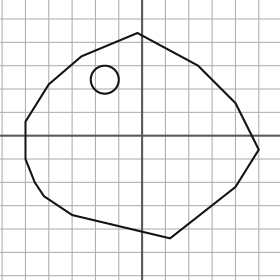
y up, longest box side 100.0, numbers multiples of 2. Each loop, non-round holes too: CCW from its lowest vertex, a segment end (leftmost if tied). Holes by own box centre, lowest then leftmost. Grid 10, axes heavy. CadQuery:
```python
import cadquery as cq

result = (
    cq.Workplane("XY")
    .moveTo(12.0, -44.0)
    .lineTo(40.0, -22.0)
    .lineTo(50.0, -6.0)
    .lineTo(40.0, 14.0)
    .lineTo(24.0, 30.0)
    .lineTo(-2.0, 44.0)
    .lineTo(-26.0, 34.0)
    .lineTo(-40.0, 22.0)
    .lineTo(-50.0, 6.0)
    .lineTo(-50.0, -10.0)
    .lineTo(-46.0, -20.0)
    .lineTo(-42.0, -26.0)
    .lineTo(-30.0, -34.0)
    .close()
    .moveTo(-16.0, 24.0)
    .circle(6.0)
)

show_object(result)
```